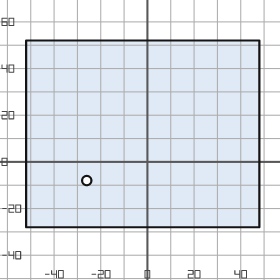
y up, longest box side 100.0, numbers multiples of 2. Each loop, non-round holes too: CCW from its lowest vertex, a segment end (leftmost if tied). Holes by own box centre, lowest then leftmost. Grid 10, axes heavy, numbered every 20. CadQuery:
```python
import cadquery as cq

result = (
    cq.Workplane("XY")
    .moveTo(-52.0, -28.0)
    .lineTo(48.0, -28.0)
    .lineTo(48.0, 52.0)
    .lineTo(-52.0, 52.0)
    .close()
    .moveTo(-26.0, -8.0)
    .circle(2.0)
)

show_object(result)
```